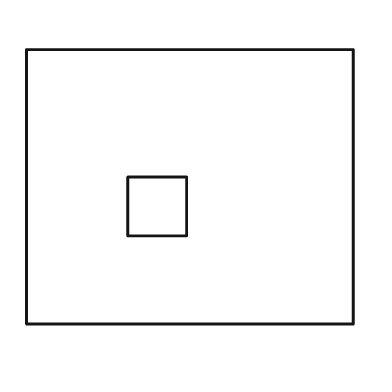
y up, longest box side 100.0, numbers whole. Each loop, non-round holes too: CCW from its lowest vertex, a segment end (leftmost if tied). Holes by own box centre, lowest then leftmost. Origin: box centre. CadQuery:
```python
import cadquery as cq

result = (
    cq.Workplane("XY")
    .moveTo(-50.0, -42.0)
    .lineTo(50.0, -42.0)
    .lineTo(50.0, 42.0)
    .lineTo(-50.0, 42.0)
    .close()
    .moveTo(-19.0, -15.0)
    .lineTo(-1.0, -15.0)
    .lineTo(-1.0, 3.0)
    .lineTo(-19.0, 3.0)
    .close()
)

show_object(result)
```